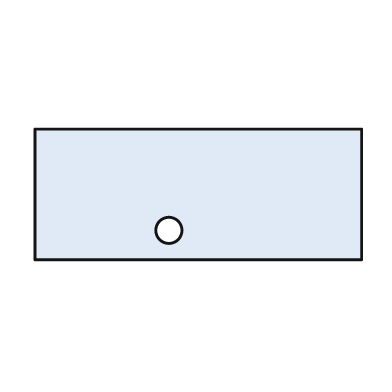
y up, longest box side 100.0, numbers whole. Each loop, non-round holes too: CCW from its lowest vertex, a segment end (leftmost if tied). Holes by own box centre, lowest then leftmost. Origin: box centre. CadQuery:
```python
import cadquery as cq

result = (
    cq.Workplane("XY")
    .moveTo(-50.0, -20.0)
    .lineTo(50.0, -20.0)
    .lineTo(50.0, 20.0)
    .lineTo(-50.0, 20.0)
    .close()
    .moveTo(-9.0, -11.0)
    .circle(4.0)
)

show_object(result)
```